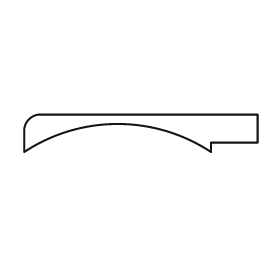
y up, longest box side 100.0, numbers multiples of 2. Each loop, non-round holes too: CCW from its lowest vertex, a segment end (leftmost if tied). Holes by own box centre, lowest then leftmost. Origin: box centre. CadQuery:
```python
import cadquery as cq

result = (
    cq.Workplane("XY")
    .moveTo(-50.0, -8.0)
    .threePointArc((-10.0, 4.0), (30.0, -8.0))
    .lineTo(30.0, -4.0)
    .lineTo(50.0, -4.0)
    .lineTo(50.0, 8.0)
    .lineTo(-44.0, 8.0)
    .threePointArc((-48.0, 6.0), (-50.0, 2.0))
    .close()
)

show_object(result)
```